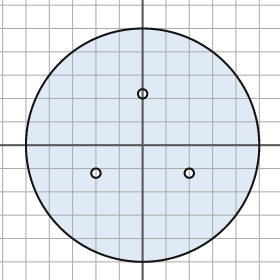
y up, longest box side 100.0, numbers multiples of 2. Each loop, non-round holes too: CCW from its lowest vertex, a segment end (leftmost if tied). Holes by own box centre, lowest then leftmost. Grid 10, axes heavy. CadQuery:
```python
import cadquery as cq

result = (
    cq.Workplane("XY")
    .moveTo(0.0, 0.0)
    .circle(50.0)
    .moveTo(-20.0, -12.0)
    .circle(2.0)
    .moveTo(20.0, -12.0)
    .circle(2.0)
    .moveTo(0.0, 22.0)
    .circle(2.0)
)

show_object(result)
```